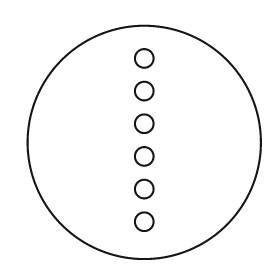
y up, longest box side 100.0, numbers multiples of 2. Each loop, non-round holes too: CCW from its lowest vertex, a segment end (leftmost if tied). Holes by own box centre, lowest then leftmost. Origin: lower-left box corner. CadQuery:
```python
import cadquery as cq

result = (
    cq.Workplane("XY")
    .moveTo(50.0, 50.0)
    .circle(50.0)
    .moveTo(50.0, 16.0)
    .circle(4.0)
    .moveTo(50.0, 30.0)
    .circle(4.0)
    .moveTo(50.0, 44.0)
    .circle(4.0)
    .moveTo(50.0, 58.0)
    .circle(4.0)
    .moveTo(50.0, 72.0)
    .circle(4.0)
    .moveTo(50.0, 86.0)
    .circle(4.0)
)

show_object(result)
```